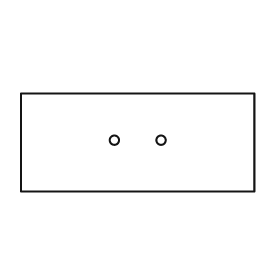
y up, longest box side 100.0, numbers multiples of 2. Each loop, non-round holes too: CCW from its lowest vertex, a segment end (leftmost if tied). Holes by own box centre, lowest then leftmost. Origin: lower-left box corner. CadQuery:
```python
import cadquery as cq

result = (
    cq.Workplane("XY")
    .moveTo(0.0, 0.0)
    .lineTo(100.0, 0.0)
    .lineTo(100.0, 42.0)
    .lineTo(0.0, 42.0)
    .close()
    .moveTo(40.0, 22.0)
    .circle(2.0)
    .moveTo(60.0, 22.0)
    .circle(2.0)
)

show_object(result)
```